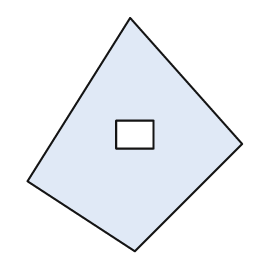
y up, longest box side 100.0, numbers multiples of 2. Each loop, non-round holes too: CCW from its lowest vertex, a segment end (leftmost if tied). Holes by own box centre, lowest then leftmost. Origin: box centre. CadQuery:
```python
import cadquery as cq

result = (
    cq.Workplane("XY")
    .moveTo(0.0, -50.0)
    .lineTo(46.0, -4.0)
    .lineTo(-2.0, 50.0)
    .lineTo(-46.0, -20.0)
    .close()
    .moveTo(-8.0, -6.0)
    .lineTo(8.0, -6.0)
    .lineTo(8.0, 6.0)
    .lineTo(-8.0, 6.0)
    .close()
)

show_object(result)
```